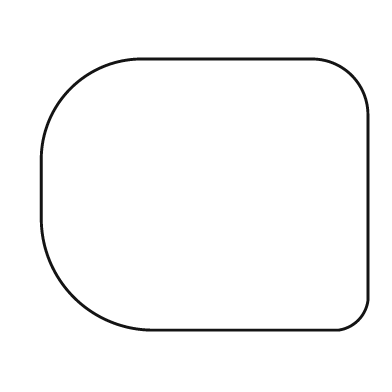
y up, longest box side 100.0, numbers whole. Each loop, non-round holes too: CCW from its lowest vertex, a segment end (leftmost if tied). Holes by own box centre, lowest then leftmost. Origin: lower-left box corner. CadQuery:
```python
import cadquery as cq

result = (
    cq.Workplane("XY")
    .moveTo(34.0, 0.0)
    .lineTo(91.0, 0.0)
    .threePointArc((97.0, 3.0), (100.0, 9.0))
    .lineTo(100.0, 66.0)
    .threePointArc((95.0, 78.0), (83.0, 83.0))
    .lineTo(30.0, 83.0)
    .threePointArc((9.0, 74.0), (0.0, 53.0))
    .lineTo(0.0, 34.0)
    .threePointArc((10.0, 10.0), (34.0, 0.0))
    .close()
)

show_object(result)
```